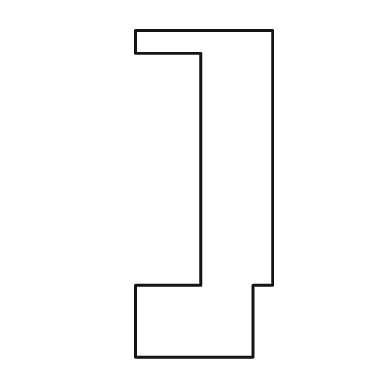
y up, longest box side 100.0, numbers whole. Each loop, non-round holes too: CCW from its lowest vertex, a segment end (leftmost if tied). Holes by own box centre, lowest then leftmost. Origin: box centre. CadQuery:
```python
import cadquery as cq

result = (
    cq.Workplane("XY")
    .moveTo(-21.0, -50.0)
    .lineTo(15.0, -50.0)
    .lineTo(15.0, -28.0)
    .lineTo(21.0, -28.0)
    .lineTo(21.0, 50.0)
    .lineTo(-21.0, 50.0)
    .lineTo(-21.0, 43.0)
    .lineTo(-1.0, 43.0)
    .lineTo(-1.0, -28.0)
    .lineTo(-21.0, -28.0)
    .close()
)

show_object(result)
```